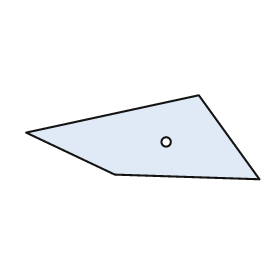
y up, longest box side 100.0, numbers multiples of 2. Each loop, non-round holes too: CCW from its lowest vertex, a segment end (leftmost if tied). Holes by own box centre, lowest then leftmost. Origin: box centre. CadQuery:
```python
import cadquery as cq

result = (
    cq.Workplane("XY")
    .moveTo(50.0, -18.0)
    .lineTo(24.0, 18.0)
    .lineTo(-50.0, 2.0)
    .lineTo(-12.0, -16.0)
    .close()
    .moveTo(10.0, -2.0)
    .circle(2.0)
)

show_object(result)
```